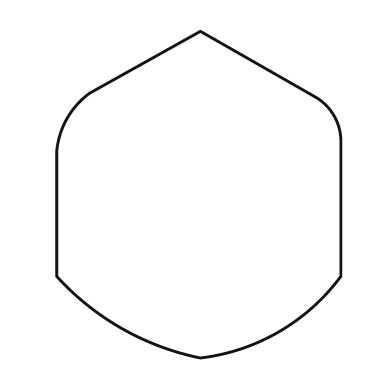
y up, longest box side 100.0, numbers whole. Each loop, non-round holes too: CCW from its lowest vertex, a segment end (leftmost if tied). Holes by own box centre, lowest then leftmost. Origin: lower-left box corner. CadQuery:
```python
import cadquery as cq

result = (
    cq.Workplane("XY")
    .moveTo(44.0, 0.0)
    .threePointArc((68.0, 8.0), (87.0, 25.0))
    .lineTo(87.0, 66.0)
    .threePointArc((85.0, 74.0), (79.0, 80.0))
    .lineTo(44.0, 100.0)
    .lineTo(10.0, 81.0)
    .threePointArc((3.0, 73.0), (0.0, 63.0))
    .lineTo(0.0, 25.0)
    .threePointArc((20.0, 9.0), (44.0, 0.0))
    .close()
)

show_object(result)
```